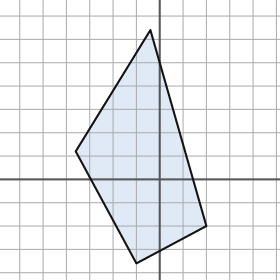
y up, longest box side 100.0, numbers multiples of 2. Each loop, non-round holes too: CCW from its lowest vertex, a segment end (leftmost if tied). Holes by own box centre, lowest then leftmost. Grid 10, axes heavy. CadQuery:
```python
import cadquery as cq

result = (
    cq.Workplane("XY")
    .moveTo(-10.0, -36.0)
    .lineTo(20.0, -20.0)
    .lineTo(-4.0, 64.0)
    .lineTo(-36.0, 12.0)
    .close()
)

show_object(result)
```